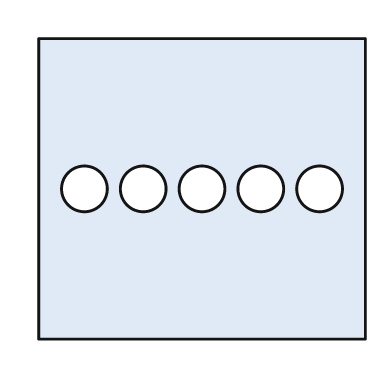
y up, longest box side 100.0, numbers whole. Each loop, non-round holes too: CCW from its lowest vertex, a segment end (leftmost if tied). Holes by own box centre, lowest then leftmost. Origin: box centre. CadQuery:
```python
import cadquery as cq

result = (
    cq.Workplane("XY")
    .moveTo(-50.0, -46.0)
    .lineTo(50.0, -46.0)
    .lineTo(50.0, 46.0)
    .lineTo(-50.0, 46.0)
    .close()
    .moveTo(-36.0, 0.0)
    .circle(7.0)
    .moveTo(-18.0, 0.0)
    .circle(7.0)
    .moveTo(0.0, 0.0)
    .circle(7.0)
    .moveTo(18.0, 0.0)
    .circle(7.0)
    .moveTo(36.0, 0.0)
    .circle(7.0)
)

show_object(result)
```